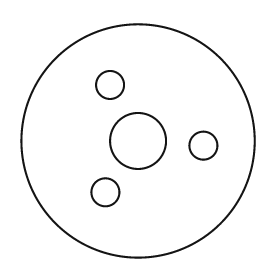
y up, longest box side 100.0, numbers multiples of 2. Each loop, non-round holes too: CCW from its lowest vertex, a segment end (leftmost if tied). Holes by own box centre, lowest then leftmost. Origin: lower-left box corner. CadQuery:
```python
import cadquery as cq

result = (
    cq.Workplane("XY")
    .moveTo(50.0, 50.0)
    .circle(50.0)
    .moveTo(36.0, 28.0)
    .circle(6.0)
    .moveTo(78.0, 48.0)
    .circle(6.0)
    .moveTo(50.0, 50.0)
    .circle(12.0)
    .moveTo(38.0, 74.0)
    .circle(6.0)
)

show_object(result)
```